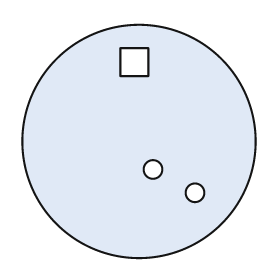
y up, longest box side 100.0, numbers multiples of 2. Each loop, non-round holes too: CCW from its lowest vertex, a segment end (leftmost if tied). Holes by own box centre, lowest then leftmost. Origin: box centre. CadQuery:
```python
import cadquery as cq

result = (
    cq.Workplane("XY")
    .moveTo(0.0, 0.0)
    .circle(50.0)
    .moveTo(24.0, -22.0)
    .circle(4.0)
    .moveTo(6.0, -12.0)
    .circle(4.0)
    .moveTo(-8.0, 28.0)
    .lineTo(4.0, 28.0)
    .lineTo(4.0, 40.0)
    .lineTo(-8.0, 40.0)
    .close()
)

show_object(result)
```